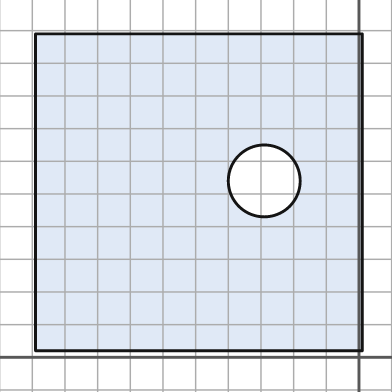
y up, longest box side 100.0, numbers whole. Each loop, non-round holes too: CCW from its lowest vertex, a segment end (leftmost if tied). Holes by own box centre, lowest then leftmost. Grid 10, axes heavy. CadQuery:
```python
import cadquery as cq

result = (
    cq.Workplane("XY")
    .moveTo(-99.0, 2.0)
    .lineTo(1.0, 2.0)
    .lineTo(1.0, 99.0)
    .lineTo(-99.0, 99.0)
    .close()
    .moveTo(-29.0, 54.0)
    .circle(11.0)
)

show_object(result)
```